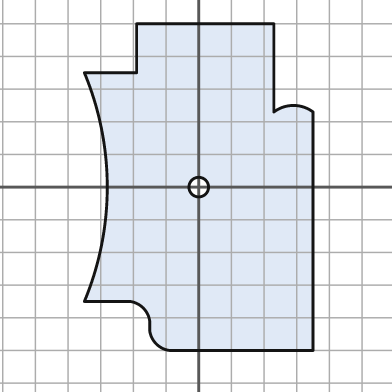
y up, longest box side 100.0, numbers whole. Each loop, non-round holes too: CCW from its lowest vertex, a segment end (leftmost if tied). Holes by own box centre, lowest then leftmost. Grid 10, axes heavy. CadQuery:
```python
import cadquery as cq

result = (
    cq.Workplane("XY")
    .moveTo(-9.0, -50.0)
    .lineTo(35.0, -50.0)
    .lineTo(35.0, 23.0)
    .threePointArc((29.0, 25.0), (23.0, 23.0))
    .lineTo(23.0, 50.0)
    .lineTo(-19.0, 50.0)
    .lineTo(-19.0, 35.0)
    .lineTo(-35.0, 35.0)
    .threePointArc((-28.0, 0.0), (-35.0, -35.0))
    .lineTo(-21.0, -35.0)
    .threePointArc((-17.0, -37.0), (-15.0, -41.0))
    .lineTo(-15.0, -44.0)
    .threePointArc((-13.0, -48.0), (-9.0, -50.0))
    .close()
    .moveTo(0.0, 0.0)
    .circle(3.0)
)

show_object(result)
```